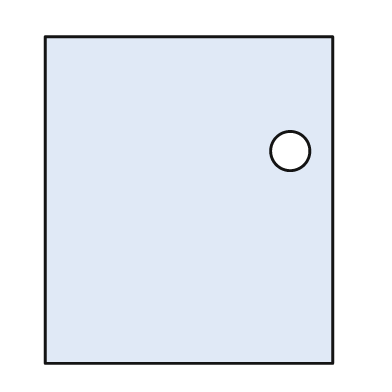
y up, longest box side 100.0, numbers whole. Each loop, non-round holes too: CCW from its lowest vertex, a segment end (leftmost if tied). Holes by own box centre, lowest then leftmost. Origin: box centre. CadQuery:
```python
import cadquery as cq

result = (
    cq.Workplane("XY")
    .moveTo(-44.0, -50.0)
    .lineTo(44.0, -50.0)
    .lineTo(44.0, 50.0)
    .lineTo(-44.0, 50.0)
    .close()
    .moveTo(31.0, 15.0)
    .circle(6.0)
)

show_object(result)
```